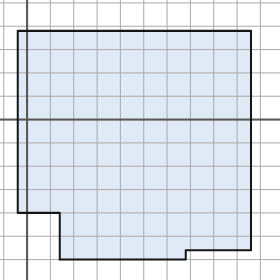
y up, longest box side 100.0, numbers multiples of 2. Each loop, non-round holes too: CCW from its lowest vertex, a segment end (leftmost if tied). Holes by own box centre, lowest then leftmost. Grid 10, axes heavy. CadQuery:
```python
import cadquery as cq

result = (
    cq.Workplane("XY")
    .moveTo(14.0, -60.0)
    .lineTo(68.0, -60.0)
    .lineTo(68.0, -56.0)
    .lineTo(96.0, -56.0)
    .lineTo(96.0, 38.0)
    .lineTo(-4.0, 38.0)
    .lineTo(-4.0, -40.0)
    .lineTo(14.0, -40.0)
    .close()
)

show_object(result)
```